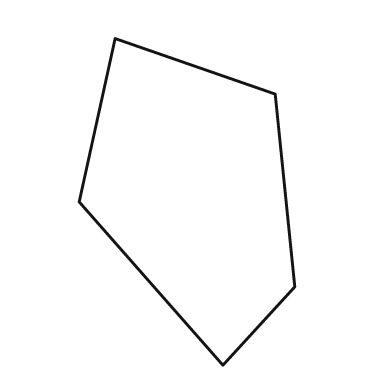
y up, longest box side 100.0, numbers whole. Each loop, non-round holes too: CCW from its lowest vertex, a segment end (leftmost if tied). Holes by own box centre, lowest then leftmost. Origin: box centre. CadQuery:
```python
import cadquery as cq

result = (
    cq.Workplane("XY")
    .moveTo(11.0, -50.0)
    .lineTo(33.0, -26.0)
    .lineTo(27.0, 33.0)
    .lineTo(-22.0, 50.0)
    .lineTo(-33.0, 0.0)
    .close()
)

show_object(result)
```